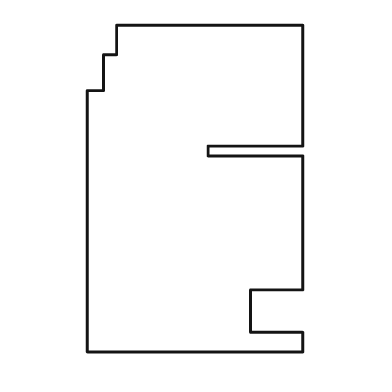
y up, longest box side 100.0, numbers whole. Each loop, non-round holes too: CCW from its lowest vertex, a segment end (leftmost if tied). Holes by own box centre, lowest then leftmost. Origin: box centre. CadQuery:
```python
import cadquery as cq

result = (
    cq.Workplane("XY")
    .moveTo(-33.0, -50.0)
    .lineTo(33.0, -50.0)
    .lineTo(33.0, -44.0)
    .lineTo(17.0, -44.0)
    .lineTo(17.0, -31.0)
    .lineTo(33.0, -31.0)
    .lineTo(33.0, 10.0)
    .lineTo(4.0, 10.0)
    .lineTo(4.0, 13.0)
    .lineTo(33.0, 13.0)
    .lineTo(33.0, 50.0)
    .lineTo(-24.0, 50.0)
    .lineTo(-24.0, 41.0)
    .lineTo(-28.0, 41.0)
    .lineTo(-28.0, 30.0)
    .lineTo(-33.0, 30.0)
    .close()
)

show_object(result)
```